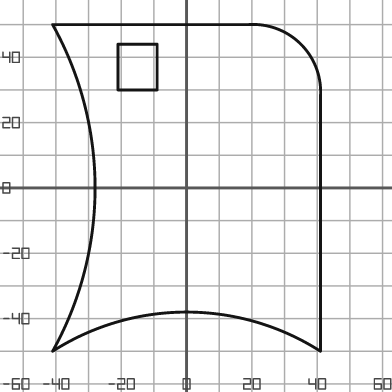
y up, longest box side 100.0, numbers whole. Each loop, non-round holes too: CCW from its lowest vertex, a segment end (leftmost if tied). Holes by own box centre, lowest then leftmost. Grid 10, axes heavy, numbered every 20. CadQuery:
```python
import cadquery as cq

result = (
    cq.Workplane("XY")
    .moveTo(-41.0, -50.0)
    .threePointArc((0.0, -38.0), (41.0, -50.0))
    .lineTo(41.0, 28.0)
    .threePointArc((35.0, 44.0), (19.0, 50.0))
    .lineTo(-41.0, 50.0)
    .threePointArc((-28.0, 0.0), (-41.0, -50.0))
    .close()
    .moveTo(-21.0, 30.0)
    .lineTo(-9.0, 30.0)
    .lineTo(-9.0, 44.0)
    .lineTo(-21.0, 44.0)
    .close()
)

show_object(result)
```